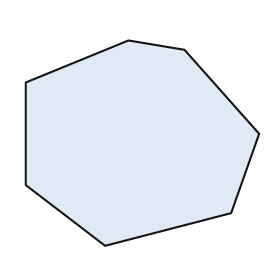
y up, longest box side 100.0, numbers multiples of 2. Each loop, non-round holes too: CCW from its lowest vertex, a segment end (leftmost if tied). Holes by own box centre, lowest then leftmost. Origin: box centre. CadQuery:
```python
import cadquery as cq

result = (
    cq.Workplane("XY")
    .moveTo(-16.0, -44.0)
    .lineTo(38.0, -30.0)
    .lineTo(50.0, 4.0)
    .lineTo(18.0, 40.0)
    .lineTo(-6.0, 44.0)
    .lineTo(-50.0, 26.0)
    .lineTo(-50.0, -18.0)
    .close()
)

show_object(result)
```